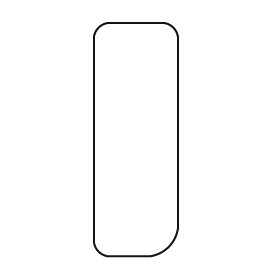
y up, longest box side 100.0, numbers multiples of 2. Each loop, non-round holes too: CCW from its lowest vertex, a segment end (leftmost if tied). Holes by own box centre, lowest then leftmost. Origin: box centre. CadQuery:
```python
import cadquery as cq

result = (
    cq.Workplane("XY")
    .moveTo(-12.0, -50.0)
    .lineTo(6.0, -50.0)
    .threePointArc((14.0, -46.0), (18.0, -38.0))
    .lineTo(18.0, 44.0)
    .threePointArc((16.0, 48.0), (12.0, 50.0))
    .lineTo(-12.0, 50.0)
    .threePointArc((-16.0, 48.0), (-18.0, 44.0))
    .lineTo(-18.0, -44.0)
    .threePointArc((-16.0, -48.0), (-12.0, -50.0))
    .close()
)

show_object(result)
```